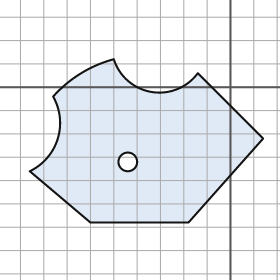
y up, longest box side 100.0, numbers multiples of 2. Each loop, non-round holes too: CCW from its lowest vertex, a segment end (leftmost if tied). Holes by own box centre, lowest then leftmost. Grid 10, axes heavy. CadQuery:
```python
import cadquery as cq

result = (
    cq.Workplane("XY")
    .moveTo(-60.0, -58.0)
    .lineTo(-18.0, -58.0)
    .lineTo(14.0, -22.0)
    .lineTo(-14.0, 6.0)
    .threePointArc((-34.0, -2.0), (-50.0, 12.0))
    .threePointArc((-64.0, 6.0), (-76.0, -4.0))
    .threePointArc((-74.0, -22.0), (-86.0, -36.0))
    .close()
    .moveTo(-44.0, -32.0)
    .circle(4.0)
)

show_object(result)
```